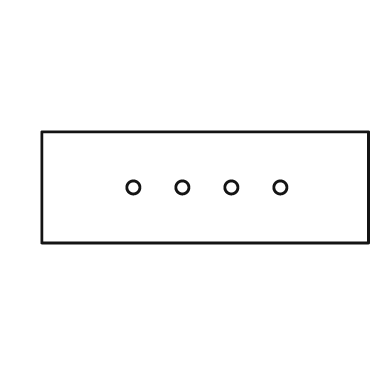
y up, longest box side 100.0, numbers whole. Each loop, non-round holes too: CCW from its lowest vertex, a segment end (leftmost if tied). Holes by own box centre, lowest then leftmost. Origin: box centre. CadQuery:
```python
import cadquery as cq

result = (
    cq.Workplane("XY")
    .moveTo(-50.0, -17.0)
    .lineTo(50.0, -17.0)
    .lineTo(50.0, 17.0)
    .lineTo(-50.0, 17.0)
    .close()
    .moveTo(-22.0, 0.0)
    .circle(2.0)
    .moveTo(-7.0, 0.0)
    .circle(2.0)
    .moveTo(8.0, 0.0)
    .circle(2.0)
    .moveTo(23.0, 0.0)
    .circle(2.0)
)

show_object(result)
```